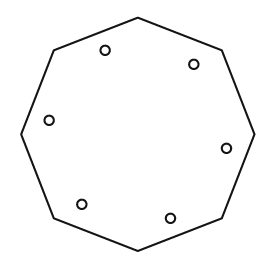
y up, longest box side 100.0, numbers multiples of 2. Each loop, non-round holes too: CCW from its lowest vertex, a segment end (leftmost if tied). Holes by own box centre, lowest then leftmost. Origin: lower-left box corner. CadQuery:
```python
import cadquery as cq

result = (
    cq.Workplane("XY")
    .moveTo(50.0, 0.0)
    .lineTo(86.0, 14.0)
    .lineTo(100.0, 50.0)
    .lineTo(86.0, 86.0)
    .lineTo(50.0, 100.0)
    .lineTo(14.0, 86.0)
    .lineTo(0.0, 50.0)
    .lineTo(14.0, 14.0)
    .close()
    .moveTo(64.0, 14.0)
    .circle(2.0)
    .moveTo(26.0, 20.0)
    .circle(2.0)
    .moveTo(88.0, 44.0)
    .circle(2.0)
    .moveTo(12.0, 56.0)
    .circle(2.0)
    .moveTo(74.0, 80.0)
    .circle(2.0)
    .moveTo(36.0, 86.0)
    .circle(2.0)
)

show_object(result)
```